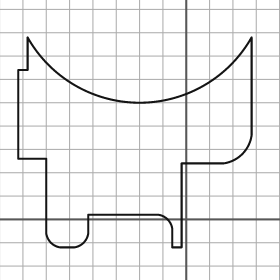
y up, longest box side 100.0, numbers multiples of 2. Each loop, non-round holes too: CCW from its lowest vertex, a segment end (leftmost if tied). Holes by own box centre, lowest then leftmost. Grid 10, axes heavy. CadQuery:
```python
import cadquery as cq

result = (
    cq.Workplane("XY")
    .moveTo(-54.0, -12.0)
    .lineTo(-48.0, -12.0)
    .threePointArc((-44.0, -10.0), (-42.0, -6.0))
    .lineTo(-42.0, 2.0)
    .lineTo(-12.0, 2.0)
    .threePointArc((-8.0, 0.0), (-6.0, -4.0))
    .lineTo(-6.0, -12.0)
    .lineTo(-2.0, -12.0)
    .lineTo(-2.0, 24.0)
    .lineTo(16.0, 24.0)
    .threePointArc((24.0, 28.0), (28.0, 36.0))
    .lineTo(28.0, 78.0)
    .threePointArc((-20.0, 50.0), (-68.0, 78.0))
    .lineTo(-68.0, 64.0)
    .lineTo(-72.0, 64.0)
    .lineTo(-72.0, 26.0)
    .lineTo(-60.0, 26.0)
    .lineTo(-60.0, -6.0)
    .threePointArc((-58.0, -10.0), (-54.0, -12.0))
    .close()
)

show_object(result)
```